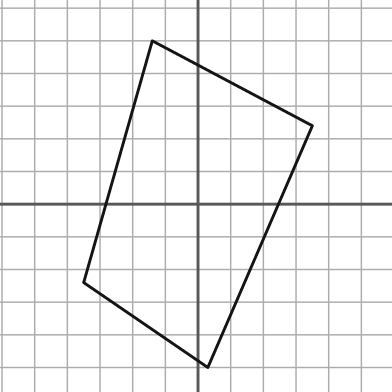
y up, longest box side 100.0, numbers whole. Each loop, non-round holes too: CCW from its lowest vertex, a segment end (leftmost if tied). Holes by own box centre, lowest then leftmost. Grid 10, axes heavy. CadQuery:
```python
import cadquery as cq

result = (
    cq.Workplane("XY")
    .moveTo(3.0, -50.0)
    .lineTo(35.0, 24.0)
    .lineTo(-14.0, 50.0)
    .lineTo(-35.0, -24.0)
    .close()
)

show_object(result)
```